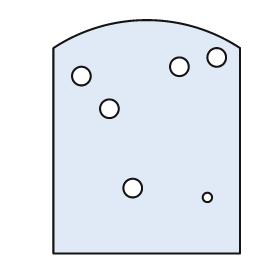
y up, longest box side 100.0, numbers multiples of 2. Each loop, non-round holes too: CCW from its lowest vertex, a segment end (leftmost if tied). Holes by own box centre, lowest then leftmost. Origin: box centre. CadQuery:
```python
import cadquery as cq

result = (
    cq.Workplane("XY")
    .moveTo(-40.0, -50.0)
    .lineTo(40.0, -50.0)
    .lineTo(40.0, 38.0)
    .threePointArc((0.0, 50.0), (-40.0, 38.0))
    .close()
    .moveTo(26.0, -26.0)
    .circle(2.0)
    .moveTo(-6.0, -22.0)
    .circle(4.0)
    .moveTo(-16.0, 12.0)
    .circle(4.0)
    .moveTo(-28.0, 26.0)
    .circle(4.0)
    .moveTo(14.0, 30.0)
    .circle(4.0)
    .moveTo(30.0, 34.0)
    .circle(4.0)
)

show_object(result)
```